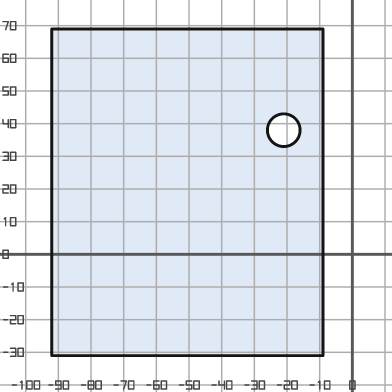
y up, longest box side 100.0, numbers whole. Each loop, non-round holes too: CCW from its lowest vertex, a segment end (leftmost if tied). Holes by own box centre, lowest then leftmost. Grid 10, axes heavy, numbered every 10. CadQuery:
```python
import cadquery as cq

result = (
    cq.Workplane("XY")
    .moveTo(-92.0, -31.0)
    .lineTo(-9.0, -31.0)
    .lineTo(-9.0, 69.0)
    .lineTo(-92.0, 69.0)
    .close()
    .moveTo(-21.0, 38.0)
    .circle(5.0)
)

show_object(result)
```